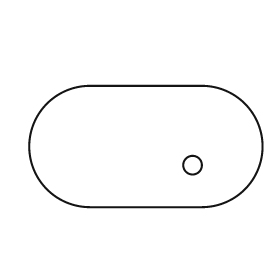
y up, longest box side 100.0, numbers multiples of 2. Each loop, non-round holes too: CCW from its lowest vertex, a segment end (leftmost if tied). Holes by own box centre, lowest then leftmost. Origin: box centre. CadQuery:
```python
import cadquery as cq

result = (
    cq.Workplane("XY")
    .moveTo(-24.0, -26.0)
    .lineTo(24.0, -26.0)
    .threePointArc((50.0, 0.0), (24.0, 26.0))
    .lineTo(-24.0, 26.0)
    .threePointArc((-50.0, 0.0), (-24.0, -26.0))
    .close()
    .moveTo(20.0, -8.0)
    .circle(4.0)
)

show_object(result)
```